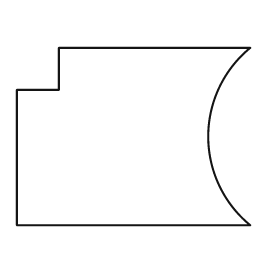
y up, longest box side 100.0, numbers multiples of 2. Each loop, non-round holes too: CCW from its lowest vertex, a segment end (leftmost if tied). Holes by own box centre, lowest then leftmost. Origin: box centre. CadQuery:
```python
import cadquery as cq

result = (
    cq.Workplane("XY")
    .moveTo(-50.0, -38.0)
    .lineTo(50.0, -38.0)
    .threePointArc((32.0, 0.0), (50.0, 38.0))
    .lineTo(-32.0, 38.0)
    .lineTo(-32.0, 20.0)
    .lineTo(-50.0, 20.0)
    .close()
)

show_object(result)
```